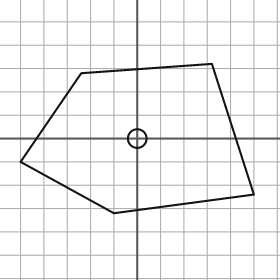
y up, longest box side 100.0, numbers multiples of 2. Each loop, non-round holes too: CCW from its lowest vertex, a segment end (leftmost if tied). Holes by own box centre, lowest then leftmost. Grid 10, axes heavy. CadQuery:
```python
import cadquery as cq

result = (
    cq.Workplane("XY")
    .moveTo(-10.0, -32.0)
    .lineTo(50.0, -24.0)
    .lineTo(32.0, 32.0)
    .lineTo(-24.0, 28.0)
    .lineTo(-50.0, -10.0)
    .close()
    .moveTo(0.0, 0.0)
    .circle(4.0)
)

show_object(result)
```